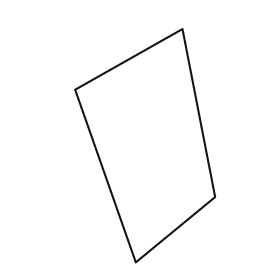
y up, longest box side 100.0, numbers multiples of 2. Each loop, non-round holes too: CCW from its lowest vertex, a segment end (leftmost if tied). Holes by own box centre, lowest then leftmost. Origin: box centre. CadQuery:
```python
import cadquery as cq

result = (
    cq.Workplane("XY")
    .moveTo(-4.0, -50.0)
    .lineTo(30.0, -22.0)
    .lineTo(16.0, 50.0)
    .lineTo(-30.0, 24.0)
    .close()
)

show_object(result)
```